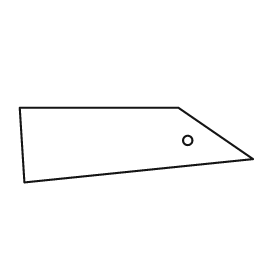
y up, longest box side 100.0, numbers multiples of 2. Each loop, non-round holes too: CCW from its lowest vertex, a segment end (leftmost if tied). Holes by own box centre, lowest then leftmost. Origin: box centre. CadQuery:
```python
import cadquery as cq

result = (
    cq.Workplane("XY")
    .moveTo(-48.0, -16.0)
    .lineTo(50.0, -6.0)
    .lineTo(18.0, 16.0)
    .lineTo(-50.0, 16.0)
    .close()
    .moveTo(22.0, 2.0)
    .circle(2.0)
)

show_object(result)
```